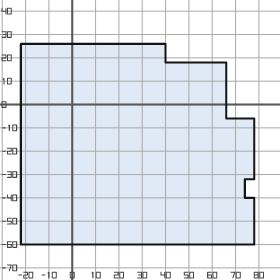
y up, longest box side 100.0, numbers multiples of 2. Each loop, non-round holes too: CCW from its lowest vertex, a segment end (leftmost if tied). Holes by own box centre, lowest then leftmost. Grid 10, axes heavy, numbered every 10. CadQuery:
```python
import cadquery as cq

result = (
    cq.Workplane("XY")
    .moveTo(-22.0, -60.0)
    .lineTo(78.0, -60.0)
    .lineTo(78.0, -40.0)
    .lineTo(74.0, -40.0)
    .lineTo(74.0, -32.0)
    .lineTo(78.0, -32.0)
    .lineTo(78.0, -6.0)
    .lineTo(66.0, -6.0)
    .lineTo(66.0, 18.0)
    .lineTo(40.0, 18.0)
    .lineTo(40.0, 26.0)
    .lineTo(-22.0, 26.0)
    .close()
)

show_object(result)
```